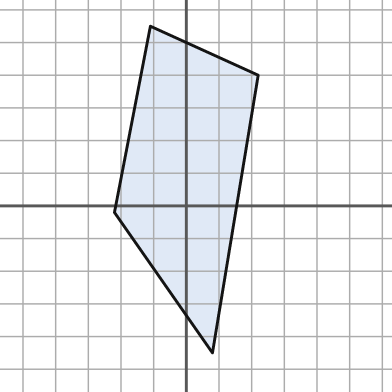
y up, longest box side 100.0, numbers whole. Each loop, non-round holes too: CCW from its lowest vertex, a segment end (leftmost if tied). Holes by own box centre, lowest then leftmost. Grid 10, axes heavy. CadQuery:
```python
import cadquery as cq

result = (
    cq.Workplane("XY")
    .moveTo(8.0, -45.0)
    .lineTo(22.0, 40.0)
    .lineTo(-11.0, 55.0)
    .lineTo(-22.0, -2.0)
    .close()
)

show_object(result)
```